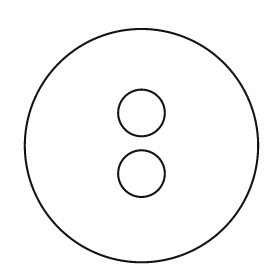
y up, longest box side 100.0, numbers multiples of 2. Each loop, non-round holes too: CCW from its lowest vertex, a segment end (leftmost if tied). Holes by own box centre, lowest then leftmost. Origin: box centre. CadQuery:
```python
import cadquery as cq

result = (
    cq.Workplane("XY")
    .moveTo(0.0, 0.0)
    .circle(50.0)
    .moveTo(0.0, -12.0)
    .circle(10.0)
    .moveTo(0.0, 14.0)
    .circle(10.0)
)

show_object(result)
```